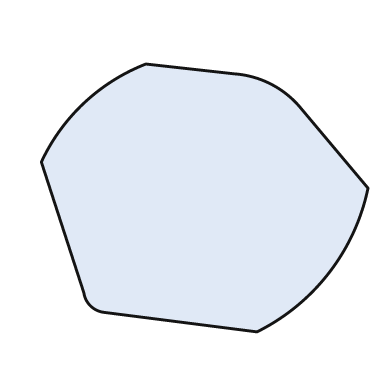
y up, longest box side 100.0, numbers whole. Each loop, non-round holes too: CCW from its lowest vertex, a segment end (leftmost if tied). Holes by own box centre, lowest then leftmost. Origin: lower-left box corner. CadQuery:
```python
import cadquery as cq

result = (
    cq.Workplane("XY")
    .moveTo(66.0, 0.0)
    .threePointArc((88.0, 18.0), (100.0, 44.0))
    .lineTo(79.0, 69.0)
    .threePointArc((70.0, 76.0), (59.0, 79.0))
    .lineTo(32.0, 82.0)
    .threePointArc((13.0, 70.0), (0.0, 52.0))
    .lineTo(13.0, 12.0)
    .threePointArc((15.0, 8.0), (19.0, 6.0))
    .close()
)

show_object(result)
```